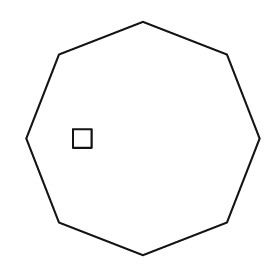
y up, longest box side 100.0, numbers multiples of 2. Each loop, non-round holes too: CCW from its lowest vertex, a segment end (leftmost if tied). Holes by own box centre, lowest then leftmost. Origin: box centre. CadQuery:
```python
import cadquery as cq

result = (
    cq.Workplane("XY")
    .moveTo(0.0, -50.0)
    .lineTo(36.0, -36.0)
    .lineTo(50.0, 0.0)
    .lineTo(36.0, 36.0)
    .lineTo(0.0, 50.0)
    .lineTo(-36.0, 36.0)
    .lineTo(-50.0, 0.0)
    .lineTo(-36.0, -36.0)
    .close()
    .moveTo(-30.0, -4.0)
    .lineTo(-22.0, -4.0)
    .lineTo(-22.0, 4.0)
    .lineTo(-30.0, 4.0)
    .close()
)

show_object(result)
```